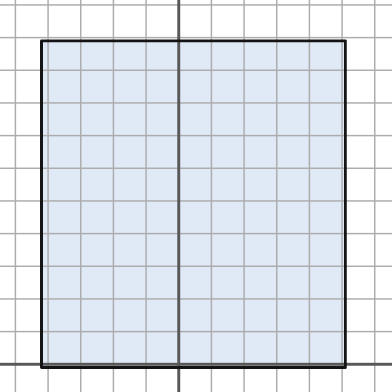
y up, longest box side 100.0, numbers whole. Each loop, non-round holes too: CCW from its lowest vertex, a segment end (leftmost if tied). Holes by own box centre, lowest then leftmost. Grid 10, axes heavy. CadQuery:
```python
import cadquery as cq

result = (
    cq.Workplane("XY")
    .moveTo(-42.0, -1.0)
    .lineTo(51.0, -1.0)
    .lineTo(51.0, 99.0)
    .lineTo(-42.0, 99.0)
    .close()
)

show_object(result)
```